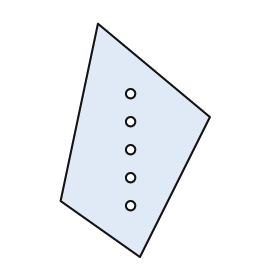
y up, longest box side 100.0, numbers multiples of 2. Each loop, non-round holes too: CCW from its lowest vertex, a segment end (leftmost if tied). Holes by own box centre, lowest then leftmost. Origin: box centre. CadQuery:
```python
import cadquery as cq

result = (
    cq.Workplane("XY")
    .moveTo(2.0, -50.0)
    .lineTo(32.0, 10.0)
    .lineTo(-16.0, 50.0)
    .lineTo(-32.0, -26.0)
    .close()
    .moveTo(-2.0, -28.0)
    .circle(2.0)
    .moveTo(-2.0, -16.0)
    .circle(2.0)
    .moveTo(-2.0, -4.0)
    .circle(2.0)
    .moveTo(-2.0, 8.0)
    .circle(2.0)
    .moveTo(-2.0, 20.0)
    .circle(2.0)
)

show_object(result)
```